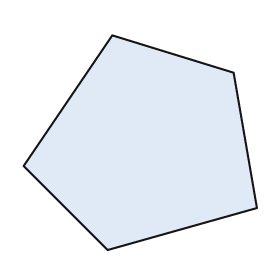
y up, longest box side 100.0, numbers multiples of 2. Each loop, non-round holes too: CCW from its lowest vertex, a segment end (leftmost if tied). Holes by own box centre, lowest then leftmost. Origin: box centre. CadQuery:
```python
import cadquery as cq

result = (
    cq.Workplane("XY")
    .moveTo(-14.0, -46.0)
    .lineTo(50.0, -28.0)
    .lineTo(40.0, 30.0)
    .lineTo(-12.0, 46.0)
    .lineTo(-50.0, -10.0)
    .close()
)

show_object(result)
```